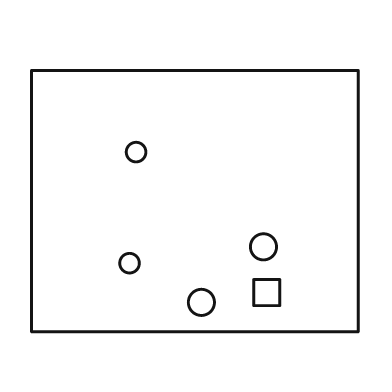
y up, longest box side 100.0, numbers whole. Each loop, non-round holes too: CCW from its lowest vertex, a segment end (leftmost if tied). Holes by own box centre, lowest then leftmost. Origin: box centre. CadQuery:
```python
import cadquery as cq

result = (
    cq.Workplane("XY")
    .moveTo(-50.0, -40.0)
    .lineTo(50.0, -40.0)
    .lineTo(50.0, 40.0)
    .lineTo(-50.0, 40.0)
    .close()
    .moveTo(2.0, -31.0)
    .circle(4.0)
    .moveTo(18.0, -32.0)
    .lineTo(26.0, -32.0)
    .lineTo(26.0, -24.0)
    .lineTo(18.0, -24.0)
    .close()
    .moveTo(-20.0, -19.0)
    .circle(3.0)
    .moveTo(21.0, -14.0)
    .circle(4.0)
    .moveTo(-18.0, 15.0)
    .circle(3.0)
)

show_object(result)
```